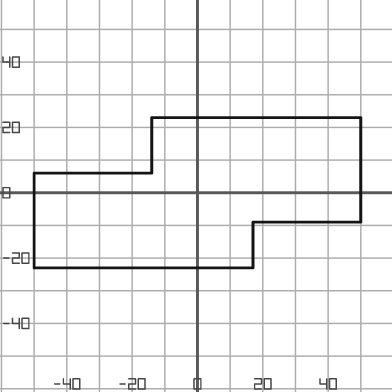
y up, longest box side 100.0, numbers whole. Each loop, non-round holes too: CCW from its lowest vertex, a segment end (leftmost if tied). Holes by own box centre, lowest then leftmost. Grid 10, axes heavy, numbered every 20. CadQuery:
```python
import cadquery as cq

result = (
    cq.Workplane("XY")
    .moveTo(-50.0, -23.0)
    .lineTo(17.0, -23.0)
    .lineTo(17.0, -9.0)
    .lineTo(50.0, -9.0)
    .lineTo(50.0, 23.0)
    .lineTo(-14.0, 23.0)
    .lineTo(-14.0, 6.0)
    .lineTo(-50.0, 6.0)
    .close()
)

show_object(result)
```